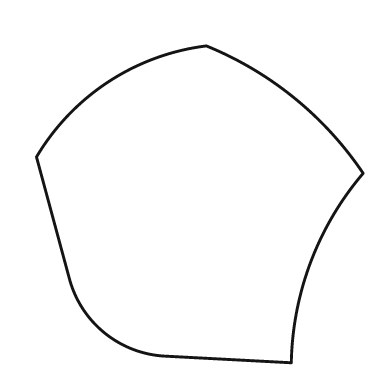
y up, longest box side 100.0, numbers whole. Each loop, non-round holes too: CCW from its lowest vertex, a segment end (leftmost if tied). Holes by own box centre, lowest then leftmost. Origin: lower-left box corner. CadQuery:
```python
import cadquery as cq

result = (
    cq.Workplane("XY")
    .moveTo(78.0, 0.0)
    .threePointArc((84.0, 31.0), (100.0, 58.0))
    .threePointArc((79.0, 81.0), (52.0, 97.0))
    .threePointArc((22.0, 86.0), (0.0, 63.0))
    .lineTo(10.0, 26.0)
    .threePointArc((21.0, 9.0), (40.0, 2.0))
    .close()
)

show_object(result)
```